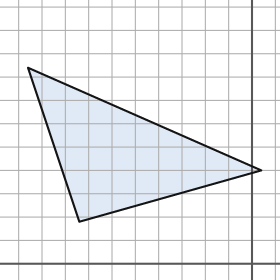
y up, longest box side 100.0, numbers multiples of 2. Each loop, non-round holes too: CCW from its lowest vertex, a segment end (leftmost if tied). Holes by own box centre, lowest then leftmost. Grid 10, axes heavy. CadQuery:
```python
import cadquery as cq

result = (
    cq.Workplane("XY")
    .moveTo(-74.0, 18.0)
    .lineTo(4.0, 40.0)
    .lineTo(-96.0, 84.0)
    .close()
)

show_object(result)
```